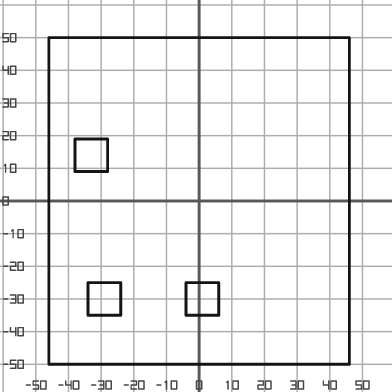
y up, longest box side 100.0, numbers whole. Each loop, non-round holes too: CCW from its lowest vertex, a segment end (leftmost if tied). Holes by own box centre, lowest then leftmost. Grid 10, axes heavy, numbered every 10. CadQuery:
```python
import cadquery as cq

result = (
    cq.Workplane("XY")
    .moveTo(-46.0, -50.0)
    .lineTo(46.0, -50.0)
    .lineTo(46.0, 50.0)
    .lineTo(-46.0, 50.0)
    .close()
    .moveTo(-34.0, -35.0)
    .lineTo(-24.0, -35.0)
    .lineTo(-24.0, -25.0)
    .lineTo(-34.0, -25.0)
    .close()
    .moveTo(-4.0, -35.0)
    .lineTo(6.0, -35.0)
    .lineTo(6.0, -25.0)
    .lineTo(-4.0, -25.0)
    .close()
    .moveTo(-38.0, 9.0)
    .lineTo(-28.0, 9.0)
    .lineTo(-28.0, 19.0)
    .lineTo(-38.0, 19.0)
    .close()
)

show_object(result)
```